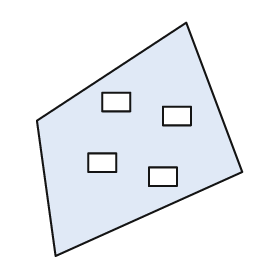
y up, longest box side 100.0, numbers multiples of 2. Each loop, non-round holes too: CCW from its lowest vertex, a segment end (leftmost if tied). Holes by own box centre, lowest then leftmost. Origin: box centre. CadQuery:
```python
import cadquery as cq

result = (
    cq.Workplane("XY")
    .moveTo(-36.0, -50.0)
    .lineTo(44.0, -14.0)
    .lineTo(20.0, 50.0)
    .lineTo(-44.0, 8.0)
    .close()
    .moveTo(4.0, -20.0)
    .lineTo(16.0, -20.0)
    .lineTo(16.0, -12.0)
    .lineTo(4.0, -12.0)
    .close()
    .moveTo(-22.0, -14.0)
    .lineTo(-10.0, -14.0)
    .lineTo(-10.0, -6.0)
    .lineTo(-22.0, -6.0)
    .close()
    .moveTo(10.0, 6.0)
    .lineTo(22.0, 6.0)
    .lineTo(22.0, 14.0)
    .lineTo(10.0, 14.0)
    .close()
    .moveTo(-16.0, 12.0)
    .lineTo(-4.0, 12.0)
    .lineTo(-4.0, 20.0)
    .lineTo(-16.0, 20.0)
    .close()
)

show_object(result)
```